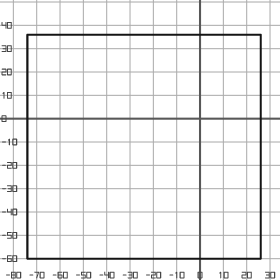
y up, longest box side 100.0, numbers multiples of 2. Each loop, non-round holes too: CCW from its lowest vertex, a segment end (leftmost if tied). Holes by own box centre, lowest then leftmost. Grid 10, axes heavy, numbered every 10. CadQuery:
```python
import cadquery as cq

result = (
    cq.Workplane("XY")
    .moveTo(-74.0, -60.0)
    .lineTo(26.0, -60.0)
    .lineTo(26.0, 36.0)
    .lineTo(-74.0, 36.0)
    .close()
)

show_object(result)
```